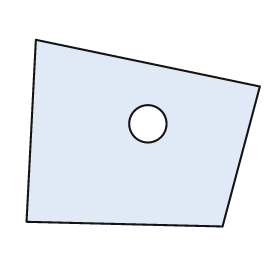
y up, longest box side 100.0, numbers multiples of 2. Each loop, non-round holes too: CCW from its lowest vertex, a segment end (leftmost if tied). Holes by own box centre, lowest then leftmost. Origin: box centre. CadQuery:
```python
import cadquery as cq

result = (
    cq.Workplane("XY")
    .moveTo(34.0, -40.0)
    .lineTo(50.0, 20.0)
    .lineTo(-46.0, 40.0)
    .lineTo(-50.0, -38.0)
    .close()
    .moveTo(2.0, 4.0)
    .circle(8.0)
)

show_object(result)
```